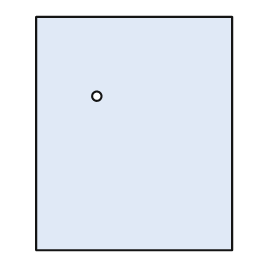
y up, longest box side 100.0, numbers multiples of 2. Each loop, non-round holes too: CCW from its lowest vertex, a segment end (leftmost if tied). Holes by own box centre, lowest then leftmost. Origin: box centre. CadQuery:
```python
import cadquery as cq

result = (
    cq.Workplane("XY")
    .moveTo(-42.0, -50.0)
    .lineTo(42.0, -50.0)
    .lineTo(42.0, 50.0)
    .lineTo(-42.0, 50.0)
    .close()
    .moveTo(-16.0, 16.0)
    .circle(2.0)
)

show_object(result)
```